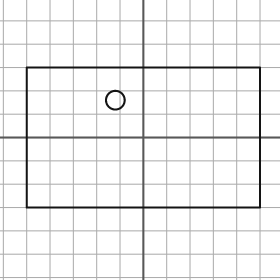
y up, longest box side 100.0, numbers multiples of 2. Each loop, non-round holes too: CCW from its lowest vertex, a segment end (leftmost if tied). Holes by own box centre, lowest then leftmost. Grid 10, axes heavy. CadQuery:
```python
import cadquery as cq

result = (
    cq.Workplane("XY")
    .moveTo(-50.0, -30.0)
    .lineTo(50.0, -30.0)
    .lineTo(50.0, 30.0)
    .lineTo(-50.0, 30.0)
    .close()
    .moveTo(-12.0, 16.0)
    .circle(4.0)
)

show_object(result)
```